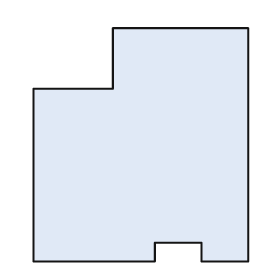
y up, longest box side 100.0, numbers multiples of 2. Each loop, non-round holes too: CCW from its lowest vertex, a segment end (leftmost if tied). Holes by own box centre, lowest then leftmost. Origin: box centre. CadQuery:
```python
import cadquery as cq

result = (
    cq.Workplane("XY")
    .moveTo(-46.0, -50.0)
    .lineTo(6.0, -50.0)
    .lineTo(6.0, -42.0)
    .lineTo(26.0, -42.0)
    .lineTo(26.0, -50.0)
    .lineTo(46.0, -50.0)
    .lineTo(46.0, 50.0)
    .lineTo(-12.0, 50.0)
    .lineTo(-12.0, 24.0)
    .lineTo(-46.0, 24.0)
    .close()
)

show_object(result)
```